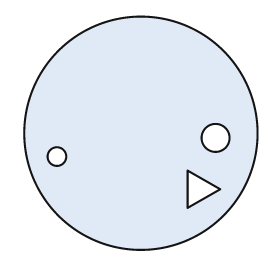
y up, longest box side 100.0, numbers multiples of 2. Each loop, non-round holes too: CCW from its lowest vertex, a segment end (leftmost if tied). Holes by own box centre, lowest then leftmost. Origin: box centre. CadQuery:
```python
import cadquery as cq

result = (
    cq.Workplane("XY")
    .moveTo(0.0, 0.0)
    .circle(50.0)
    .moveTo(20.0, -32.0)
    .lineTo(34.0, -24.0)
    .lineTo(20.0, -16.0)
    .close()
    .moveTo(-36.0, -10.0)
    .circle(4.0)
    .moveTo(32.0, -2.0)
    .circle(6.0)
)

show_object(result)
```